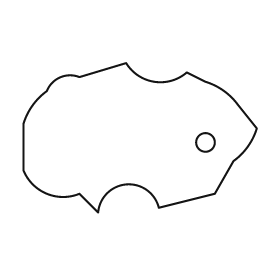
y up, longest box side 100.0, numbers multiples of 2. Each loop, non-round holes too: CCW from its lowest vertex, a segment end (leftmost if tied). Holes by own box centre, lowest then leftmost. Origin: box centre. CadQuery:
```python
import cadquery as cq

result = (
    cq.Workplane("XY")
    .moveTo(-18.0, -32.0)
    .threePointArc((-6.0, -20.0), (8.0, -30.0))
    .lineTo(32.0, -24.0)
    .lineTo(40.0, -10.0)
    .threePointArc((46.0, -4.0), (50.0, 4.0))
    .lineTo(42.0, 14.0)
    .threePointArc((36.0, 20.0), (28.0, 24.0))
    .lineTo(20.0, 28.0)
    .threePointArc((6.0, 24.0), (-6.0, 32.0))
    .lineTo(-26.0, 26.0)
    .threePointArc((-34.0, 26.0), (-40.0, 20.0))
    .threePointArc((-46.0, 14.0), (-50.0, 6.0))
    .lineTo(-50.0, -14.0)
    .threePointArc((-40.0, -24.0), (-26.0, -24.0))
    .close()
    .moveTo(28.0, -2.0)
    .circle(4.0)
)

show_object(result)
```